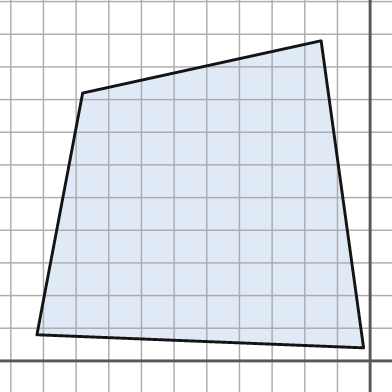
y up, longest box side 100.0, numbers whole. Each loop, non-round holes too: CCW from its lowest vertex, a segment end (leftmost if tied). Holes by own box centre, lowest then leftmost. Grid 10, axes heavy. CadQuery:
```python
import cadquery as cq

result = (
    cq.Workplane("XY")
    .moveTo(-2.0, 4.0)
    .lineTo(-15.0, 98.0)
    .lineTo(-88.0, 82.0)
    .lineTo(-102.0, 8.0)
    .close()
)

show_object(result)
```